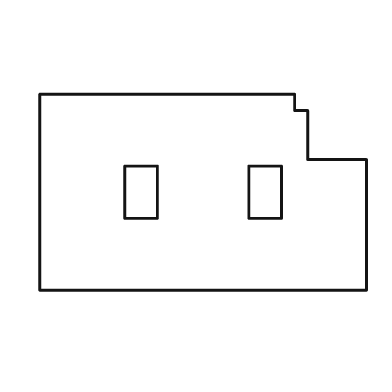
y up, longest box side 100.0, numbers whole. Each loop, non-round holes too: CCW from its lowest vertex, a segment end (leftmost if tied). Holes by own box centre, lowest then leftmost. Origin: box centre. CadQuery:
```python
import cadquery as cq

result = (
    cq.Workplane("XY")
    .moveTo(-50.0, -30.0)
    .lineTo(50.0, -30.0)
    .lineTo(50.0, 10.0)
    .lineTo(32.0, 10.0)
    .lineTo(32.0, 25.0)
    .lineTo(28.0, 25.0)
    .lineTo(28.0, 30.0)
    .lineTo(-50.0, 30.0)
    .close()
    .moveTo(-24.0, -8.0)
    .lineTo(-14.0, -8.0)
    .lineTo(-14.0, 8.0)
    .lineTo(-24.0, 8.0)
    .close()
    .moveTo(14.0, -8.0)
    .lineTo(24.0, -8.0)
    .lineTo(24.0, 8.0)
    .lineTo(14.0, 8.0)
    .close()
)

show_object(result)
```